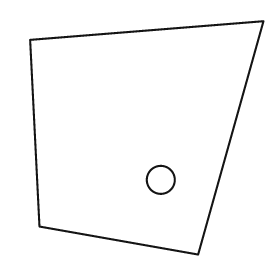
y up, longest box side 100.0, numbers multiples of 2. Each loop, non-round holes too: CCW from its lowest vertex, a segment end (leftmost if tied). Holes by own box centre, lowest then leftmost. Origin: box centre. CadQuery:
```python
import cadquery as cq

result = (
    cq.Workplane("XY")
    .moveTo(22.0, -50.0)
    .lineTo(50.0, 50.0)
    .lineTo(-50.0, 42.0)
    .lineTo(-46.0, -38.0)
    .close()
    .moveTo(6.0, -18.0)
    .circle(6.0)
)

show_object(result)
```